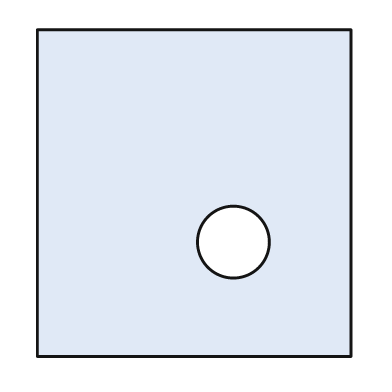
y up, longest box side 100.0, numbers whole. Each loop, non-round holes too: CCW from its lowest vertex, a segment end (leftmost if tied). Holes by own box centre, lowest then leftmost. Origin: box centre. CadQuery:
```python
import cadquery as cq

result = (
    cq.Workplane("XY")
    .moveTo(-48.0, -50.0)
    .lineTo(48.0, -50.0)
    .lineTo(48.0, 50.0)
    .lineTo(-48.0, 50.0)
    .close()
    .moveTo(12.0, -15.0)
    .circle(11.0)
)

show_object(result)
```